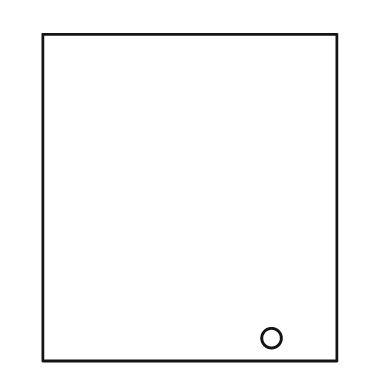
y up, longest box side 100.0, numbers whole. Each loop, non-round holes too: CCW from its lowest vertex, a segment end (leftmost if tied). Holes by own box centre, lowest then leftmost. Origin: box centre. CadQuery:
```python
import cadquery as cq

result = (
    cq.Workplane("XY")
    .moveTo(-45.0, -50.0)
    .lineTo(45.0, -50.0)
    .lineTo(45.0, 50.0)
    .lineTo(-45.0, 50.0)
    .close()
    .moveTo(25.0, -43.0)
    .circle(3.0)
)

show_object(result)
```